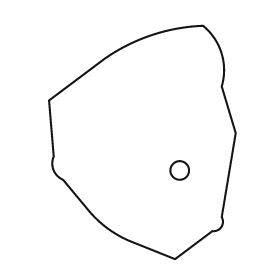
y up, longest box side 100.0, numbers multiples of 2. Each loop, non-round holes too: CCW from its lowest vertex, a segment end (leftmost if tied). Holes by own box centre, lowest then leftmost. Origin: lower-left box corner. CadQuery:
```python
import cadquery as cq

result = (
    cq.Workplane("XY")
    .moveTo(54.0, 0.0)
    .lineTo(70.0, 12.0)
    .threePointArc((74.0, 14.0), (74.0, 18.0))
    .lineTo(80.0, 54.0)
    .lineTo(74.0, 74.0)
    .threePointArc((74.0, 88.0), (66.0, 100.0))
    .threePointArc((44.0, 96.0), (24.0, 86.0))
    .lineTo(0.0, 68.0)
    .lineTo(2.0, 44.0)
    .threePointArc((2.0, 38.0), (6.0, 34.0))
    .lineTo(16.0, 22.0)
    .threePointArc((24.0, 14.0), (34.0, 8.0))
    .close()
    .moveTo(56.0, 38.0)
    .circle(4.0)
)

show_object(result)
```